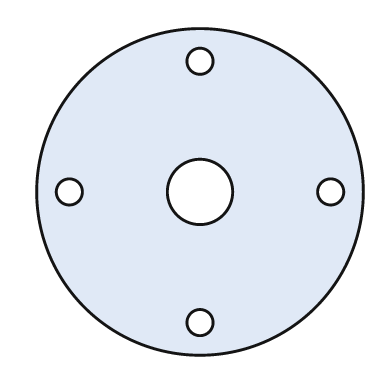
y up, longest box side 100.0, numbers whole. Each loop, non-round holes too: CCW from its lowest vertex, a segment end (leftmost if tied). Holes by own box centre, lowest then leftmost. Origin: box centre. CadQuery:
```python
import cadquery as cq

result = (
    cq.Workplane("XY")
    .moveTo(0.0, 0.0)
    .circle(50.0)
    .moveTo(0.0, -40.0)
    .circle(4.0)
    .moveTo(-40.0, 0.0)
    .circle(4.0)
    .moveTo(0.0, 0.0)
    .circle(10.0)
    .moveTo(40.0, 0.0)
    .circle(4.0)
    .moveTo(0.0, 40.0)
    .circle(4.0)
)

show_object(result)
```